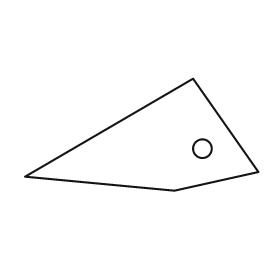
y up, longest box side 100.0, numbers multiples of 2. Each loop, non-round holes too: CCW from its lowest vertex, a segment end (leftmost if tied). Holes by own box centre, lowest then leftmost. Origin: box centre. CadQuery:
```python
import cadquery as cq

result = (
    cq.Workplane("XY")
    .moveTo(14.0, -24.0)
    .lineTo(50.0, -16.0)
    .lineTo(22.0, 24.0)
    .lineTo(-50.0, -18.0)
    .close()
    .moveTo(26.0, -6.0)
    .circle(4.0)
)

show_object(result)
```